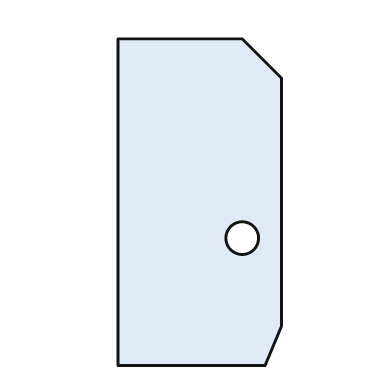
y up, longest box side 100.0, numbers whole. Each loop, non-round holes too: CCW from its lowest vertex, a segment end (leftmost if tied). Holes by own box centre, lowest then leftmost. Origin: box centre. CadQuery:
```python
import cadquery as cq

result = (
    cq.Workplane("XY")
    .moveTo(-25.0, -50.0)
    .lineTo(20.0, -50.0)
    .lineTo(25.0, -38.0)
    .lineTo(25.0, 38.0)
    .lineTo(13.0, 50.0)
    .lineTo(-25.0, 50.0)
    .close()
    .moveTo(13.0, -11.0)
    .circle(5.0)
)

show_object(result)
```